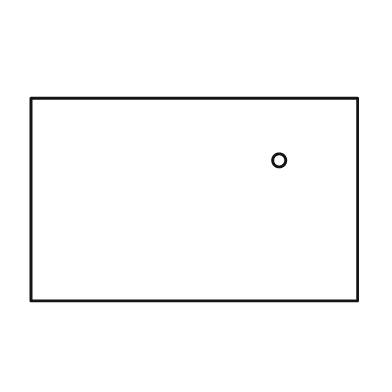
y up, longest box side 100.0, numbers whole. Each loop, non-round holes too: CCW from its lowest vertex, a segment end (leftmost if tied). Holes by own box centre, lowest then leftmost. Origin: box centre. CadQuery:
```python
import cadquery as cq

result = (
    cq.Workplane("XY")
    .moveTo(-50.0, -31.0)
    .lineTo(50.0, -31.0)
    .lineTo(50.0, 31.0)
    .lineTo(-50.0, 31.0)
    .close()
    .moveTo(26.0, 12.0)
    .circle(2.0)
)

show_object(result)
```